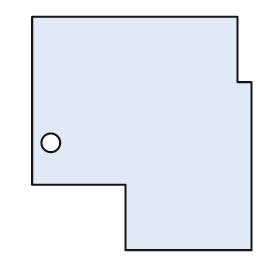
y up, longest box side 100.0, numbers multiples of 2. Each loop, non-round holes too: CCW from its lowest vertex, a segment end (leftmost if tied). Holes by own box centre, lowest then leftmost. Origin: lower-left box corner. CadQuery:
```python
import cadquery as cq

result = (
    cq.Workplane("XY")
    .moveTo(40.0, 0.0)
    .lineTo(94.0, 0.0)
    .lineTo(94.0, 72.0)
    .lineTo(88.0, 72.0)
    .lineTo(88.0, 100.0)
    .lineTo(0.0, 100.0)
    .lineTo(0.0, 28.0)
    .lineTo(40.0, 28.0)
    .close()
    .moveTo(8.0, 46.0)
    .circle(4.0)
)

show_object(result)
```